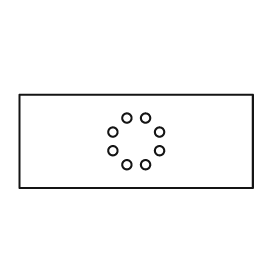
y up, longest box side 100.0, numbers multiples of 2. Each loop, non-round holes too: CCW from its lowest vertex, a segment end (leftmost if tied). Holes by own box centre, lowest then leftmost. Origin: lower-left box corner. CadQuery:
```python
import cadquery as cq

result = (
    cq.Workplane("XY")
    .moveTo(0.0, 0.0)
    .lineTo(100.0, 0.0)
    .lineTo(100.0, 40.0)
    .lineTo(0.0, 40.0)
    .close()
    .moveTo(46.0, 10.0)
    .circle(2.0)
    .moveTo(54.0, 10.0)
    .circle(2.0)
    .moveTo(40.0, 16.0)
    .circle(2.0)
    .moveTo(60.0, 16.0)
    .circle(2.0)
    .moveTo(40.0, 24.0)
    .circle(2.0)
    .moveTo(60.0, 24.0)
    .circle(2.0)
    .moveTo(46.0, 30.0)
    .circle(2.0)
    .moveTo(54.0, 30.0)
    .circle(2.0)
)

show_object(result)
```